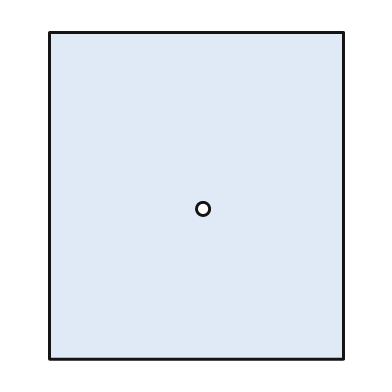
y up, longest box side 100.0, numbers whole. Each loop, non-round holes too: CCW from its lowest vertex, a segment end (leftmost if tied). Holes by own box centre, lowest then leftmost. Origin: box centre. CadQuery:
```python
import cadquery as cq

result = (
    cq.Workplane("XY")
    .moveTo(-45.0, -50.0)
    .lineTo(45.0, -50.0)
    .lineTo(45.0, 50.0)
    .lineTo(-45.0, 50.0)
    .close()
    .moveTo(2.0, -4.0)
    .circle(2.0)
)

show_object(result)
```